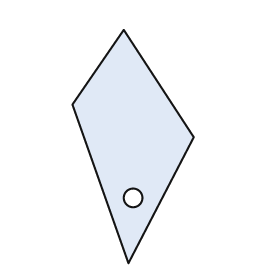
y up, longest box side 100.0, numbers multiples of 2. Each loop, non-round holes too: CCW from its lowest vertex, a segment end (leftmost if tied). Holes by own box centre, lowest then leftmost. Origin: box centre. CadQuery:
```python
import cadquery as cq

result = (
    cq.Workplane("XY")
    .moveTo(-2.0, -50.0)
    .lineTo(26.0, 4.0)
    .lineTo(-4.0, 50.0)
    .lineTo(-26.0, 18.0)
    .close()
    .moveTo(0.0, -22.0)
    .circle(4.0)
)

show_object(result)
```